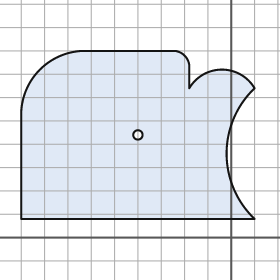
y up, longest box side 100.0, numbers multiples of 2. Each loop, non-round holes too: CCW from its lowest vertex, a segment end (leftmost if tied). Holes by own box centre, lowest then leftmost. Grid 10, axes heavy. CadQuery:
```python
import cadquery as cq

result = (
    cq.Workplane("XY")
    .moveTo(-90.0, 8.0)
    .lineTo(10.0, 8.0)
    .threePointArc((-2.0, 36.0), (10.0, 64.0))
    .threePointArc((-4.0, 72.0), (-18.0, 64.0))
    .lineTo(-18.0, 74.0)
    .threePointArc((-20.0, 78.0), (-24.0, 80.0))
    .lineTo(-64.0, 80.0)
    .threePointArc((-82.0, 72.0), (-90.0, 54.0))
    .close()
    .moveTo(-40.0, 44.0)
    .circle(2.0)
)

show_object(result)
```